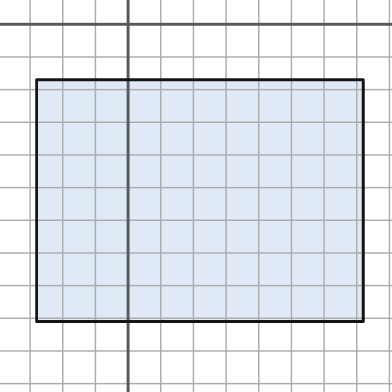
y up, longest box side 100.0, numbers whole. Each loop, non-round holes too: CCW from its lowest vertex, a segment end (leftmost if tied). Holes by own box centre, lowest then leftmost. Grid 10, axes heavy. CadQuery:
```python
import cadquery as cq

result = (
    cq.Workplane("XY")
    .moveTo(-28.0, -91.0)
    .lineTo(72.0, -91.0)
    .lineTo(72.0, -17.0)
    .lineTo(-28.0, -17.0)
    .close()
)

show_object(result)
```